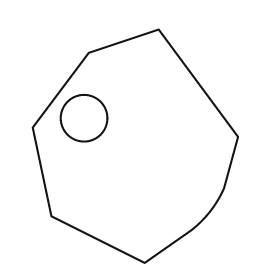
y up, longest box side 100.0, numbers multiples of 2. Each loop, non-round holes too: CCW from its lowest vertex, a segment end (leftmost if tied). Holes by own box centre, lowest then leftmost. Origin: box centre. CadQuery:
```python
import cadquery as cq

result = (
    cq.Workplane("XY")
    .moveTo(4.0, -50.0)
    .lineTo(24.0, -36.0)
    .threePointArc((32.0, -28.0), (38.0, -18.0))
    .lineTo(44.0, 4.0)
    .lineTo(10.0, 50.0)
    .lineTo(-20.0, 40.0)
    .lineTo(-44.0, 8.0)
    .lineTo(-36.0, -30.0)
    .close()
    .moveTo(-22.0, 12.0)
    .circle(10.0)
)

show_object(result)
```